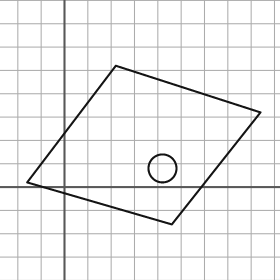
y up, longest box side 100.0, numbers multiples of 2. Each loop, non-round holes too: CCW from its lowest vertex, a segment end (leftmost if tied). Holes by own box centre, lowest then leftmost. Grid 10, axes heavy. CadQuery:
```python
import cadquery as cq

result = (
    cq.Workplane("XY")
    .moveTo(46.0, -16.0)
    .lineTo(84.0, 32.0)
    .lineTo(22.0, 52.0)
    .lineTo(-16.0, 2.0)
    .close()
    .moveTo(42.0, 8.0)
    .circle(6.0)
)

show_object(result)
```